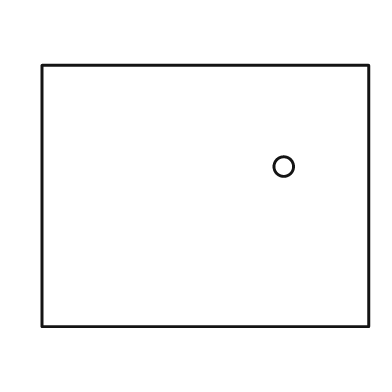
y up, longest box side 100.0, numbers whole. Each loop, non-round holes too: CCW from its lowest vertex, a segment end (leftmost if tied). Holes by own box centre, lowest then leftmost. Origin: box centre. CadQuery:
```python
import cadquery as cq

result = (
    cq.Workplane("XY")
    .moveTo(-50.0, -40.0)
    .lineTo(50.0, -40.0)
    .lineTo(50.0, 40.0)
    .lineTo(-50.0, 40.0)
    .close()
    .moveTo(24.0, 9.0)
    .circle(3.0)
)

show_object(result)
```